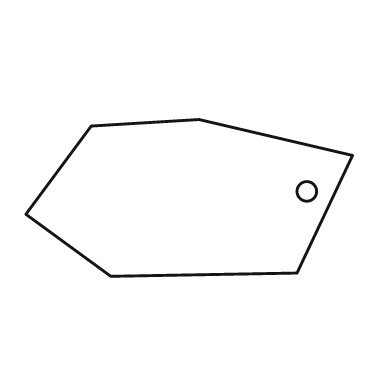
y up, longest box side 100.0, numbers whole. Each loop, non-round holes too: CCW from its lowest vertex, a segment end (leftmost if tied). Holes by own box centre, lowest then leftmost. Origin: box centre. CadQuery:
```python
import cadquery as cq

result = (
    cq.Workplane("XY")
    .moveTo(-24.0, -24.0)
    .lineTo(33.0, -23.0)
    .lineTo(50.0, 13.0)
    .lineTo(3.0, 24.0)
    .lineTo(-30.0, 22.0)
    .lineTo(-50.0, -5.0)
    .close()
    .moveTo(36.0, 2.0)
    .circle(3.0)
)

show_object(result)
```